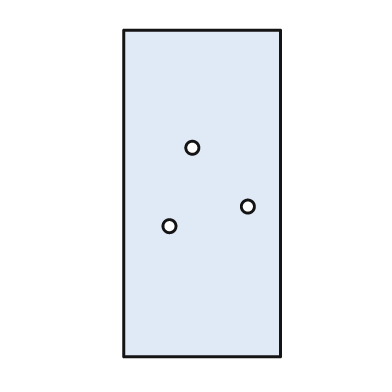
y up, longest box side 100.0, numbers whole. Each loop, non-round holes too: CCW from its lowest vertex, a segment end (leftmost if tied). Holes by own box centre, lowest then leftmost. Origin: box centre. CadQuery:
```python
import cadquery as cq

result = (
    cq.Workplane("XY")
    .moveTo(-24.0, -50.0)
    .lineTo(24.0, -50.0)
    .lineTo(24.0, 50.0)
    .lineTo(-24.0, 50.0)
    .close()
    .moveTo(-10.0, -10.0)
    .circle(2.0)
    .moveTo(14.0, -4.0)
    .circle(2.0)
    .moveTo(-3.0, 14.0)
    .circle(2.0)
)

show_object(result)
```